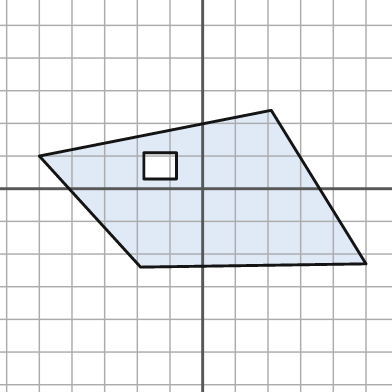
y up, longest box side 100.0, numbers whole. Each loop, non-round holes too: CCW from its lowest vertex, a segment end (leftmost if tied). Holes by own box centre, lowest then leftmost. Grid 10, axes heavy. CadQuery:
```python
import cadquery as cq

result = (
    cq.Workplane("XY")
    .moveTo(-19.0, -24.0)
    .lineTo(50.0, -23.0)
    .lineTo(21.0, 24.0)
    .lineTo(-50.0, 10.0)
    .close()
    .moveTo(-18.0, 3.0)
    .lineTo(-8.0, 3.0)
    .lineTo(-8.0, 11.0)
    .lineTo(-18.0, 11.0)
    .close()
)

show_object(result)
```